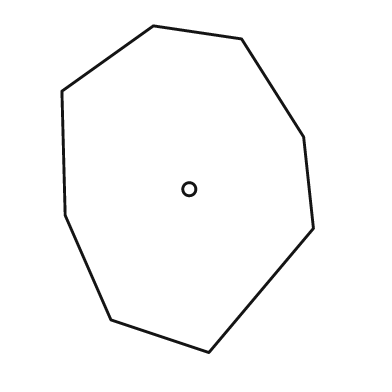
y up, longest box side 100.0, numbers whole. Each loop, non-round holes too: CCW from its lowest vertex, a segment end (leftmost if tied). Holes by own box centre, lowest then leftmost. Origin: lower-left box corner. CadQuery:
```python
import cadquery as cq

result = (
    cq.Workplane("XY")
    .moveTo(45.0, 0.0)
    .lineTo(77.0, 38.0)
    .lineTo(74.0, 66.0)
    .lineTo(55.0, 96.0)
    .lineTo(28.0, 100.0)
    .lineTo(0.0, 80.0)
    .lineTo(1.0, 42.0)
    .lineTo(15.0, 10.0)
    .close()
    .moveTo(39.0, 50.0)
    .circle(2.0)
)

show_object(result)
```